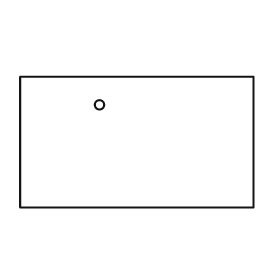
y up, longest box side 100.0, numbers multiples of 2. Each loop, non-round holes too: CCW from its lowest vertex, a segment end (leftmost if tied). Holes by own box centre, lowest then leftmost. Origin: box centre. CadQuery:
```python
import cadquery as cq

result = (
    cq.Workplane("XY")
    .moveTo(-50.0, -28.0)
    .lineTo(50.0, -28.0)
    .lineTo(50.0, 28.0)
    .lineTo(-50.0, 28.0)
    .close()
    .moveTo(-16.0, 16.0)
    .circle(2.0)
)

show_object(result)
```